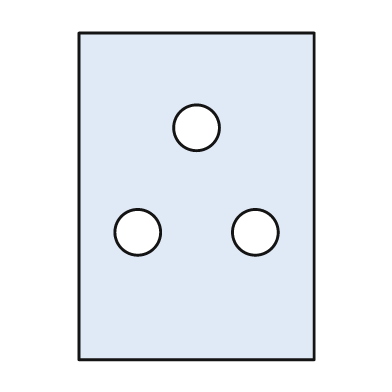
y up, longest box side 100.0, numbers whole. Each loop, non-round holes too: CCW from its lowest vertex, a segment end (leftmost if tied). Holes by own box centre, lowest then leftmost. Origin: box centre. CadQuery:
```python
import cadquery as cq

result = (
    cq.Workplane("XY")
    .moveTo(-36.0, -50.0)
    .lineTo(36.0, -50.0)
    .lineTo(36.0, 50.0)
    .lineTo(-36.0, 50.0)
    .close()
    .moveTo(-18.0, -11.0)
    .circle(7.0)
    .moveTo(18.0, -11.0)
    .circle(7.0)
    .moveTo(0.0, 21.0)
    .circle(7.0)
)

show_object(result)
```